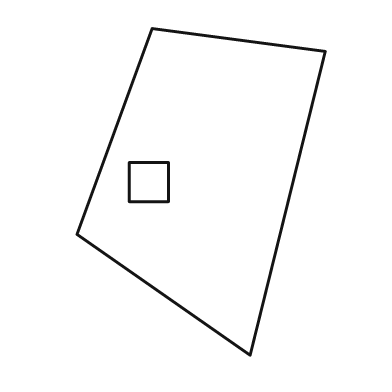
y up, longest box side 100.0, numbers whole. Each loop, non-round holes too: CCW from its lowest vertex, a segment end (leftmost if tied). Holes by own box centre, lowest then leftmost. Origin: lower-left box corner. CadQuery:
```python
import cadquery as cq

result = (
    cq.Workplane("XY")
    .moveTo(53.0, 0.0)
    .lineTo(76.0, 93.0)
    .lineTo(23.0, 100.0)
    .lineTo(0.0, 37.0)
    .close()
    .moveTo(16.0, 47.0)
    .lineTo(28.0, 47.0)
    .lineTo(28.0, 59.0)
    .lineTo(16.0, 59.0)
    .close()
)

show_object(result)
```